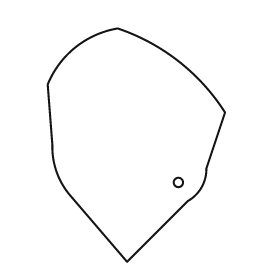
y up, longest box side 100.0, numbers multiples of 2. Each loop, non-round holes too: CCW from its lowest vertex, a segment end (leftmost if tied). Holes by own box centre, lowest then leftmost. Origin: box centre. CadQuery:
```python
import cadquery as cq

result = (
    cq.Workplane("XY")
    .moveTo(-4.0, -50.0)
    .lineTo(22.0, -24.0)
    .threePointArc((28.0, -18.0), (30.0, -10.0))
    .lineTo(38.0, 14.0)
    .threePointArc((18.0, 36.0), (-8.0, 50.0))
    .threePointArc((-26.0, 42.0), (-38.0, 26.0))
    .lineTo(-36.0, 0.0)
    .threePointArc((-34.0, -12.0), (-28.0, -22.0))
    .close()
    .moveTo(18.0, -16.0)
    .circle(2.0)
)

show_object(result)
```